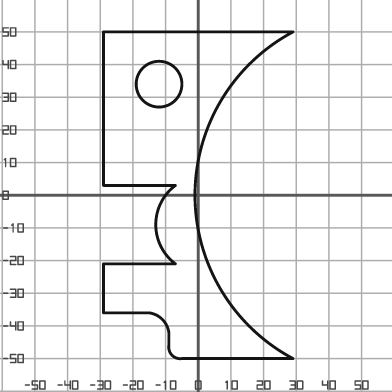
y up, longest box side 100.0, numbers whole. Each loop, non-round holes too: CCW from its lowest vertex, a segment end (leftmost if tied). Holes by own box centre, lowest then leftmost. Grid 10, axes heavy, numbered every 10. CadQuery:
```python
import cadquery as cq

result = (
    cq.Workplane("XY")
    .moveTo(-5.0, -50.0)
    .lineTo(29.0, -50.0)
    .threePointArc((-1.0, 0.0), (29.0, 50.0))
    .lineTo(-29.0, 50.0)
    .lineTo(-29.0, 3.0)
    .lineTo(-7.0, 3.0)
    .threePointArc((-13.0, -9.0), (-7.0, -21.0))
    .lineTo(-29.0, -21.0)
    .lineTo(-29.0, -36.0)
    .lineTo(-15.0, -36.0)
    .threePointArc((-11.0, -38.0), (-9.0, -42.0))
    .lineTo(-9.0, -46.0)
    .threePointArc((-8.0, -49.0), (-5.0, -50.0))
    .close()
    .moveTo(-12.0, 34.0)
    .circle(7.0)
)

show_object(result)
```